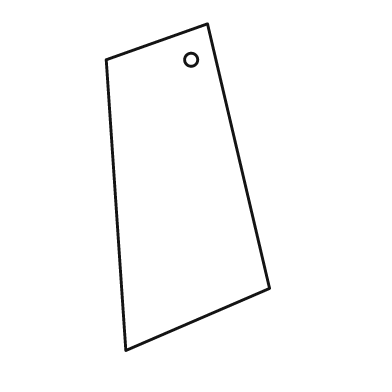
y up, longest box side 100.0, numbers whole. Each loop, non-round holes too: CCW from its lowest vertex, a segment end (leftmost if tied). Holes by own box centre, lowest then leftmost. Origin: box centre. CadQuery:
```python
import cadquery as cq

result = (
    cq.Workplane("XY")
    .moveTo(-19.0, -50.0)
    .lineTo(25.0, -31.0)
    .lineTo(6.0, 50.0)
    .lineTo(-25.0, 39.0)
    .close()
    .moveTo(1.0, 39.0)
    .circle(2.0)
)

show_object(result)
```